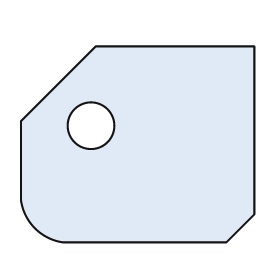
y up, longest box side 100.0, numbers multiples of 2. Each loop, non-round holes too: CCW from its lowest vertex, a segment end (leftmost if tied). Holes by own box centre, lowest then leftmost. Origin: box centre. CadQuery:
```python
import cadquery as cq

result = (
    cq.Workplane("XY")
    .moveTo(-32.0, -42.0)
    .lineTo(38.0, -42.0)
    .lineTo(50.0, -30.0)
    .lineTo(50.0, 42.0)
    .lineTo(-18.0, 42.0)
    .lineTo(-50.0, 10.0)
    .lineTo(-50.0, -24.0)
    .threePointArc((-44.0, -36.0), (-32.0, -42.0))
    .close()
    .moveTo(-20.0, 8.0)
    .circle(10.0)
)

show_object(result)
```